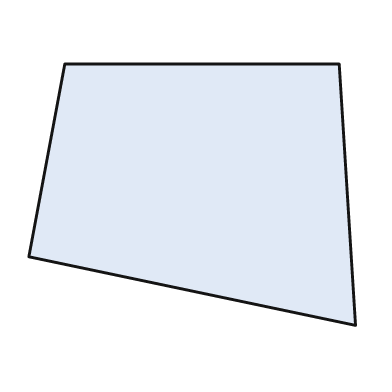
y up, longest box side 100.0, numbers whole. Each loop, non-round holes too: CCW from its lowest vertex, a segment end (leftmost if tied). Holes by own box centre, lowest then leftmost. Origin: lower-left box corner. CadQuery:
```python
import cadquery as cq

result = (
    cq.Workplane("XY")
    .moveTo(100.0, 0.0)
    .lineTo(95.0, 80.0)
    .lineTo(11.0, 80.0)
    .lineTo(0.0, 21.0)
    .close()
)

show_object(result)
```